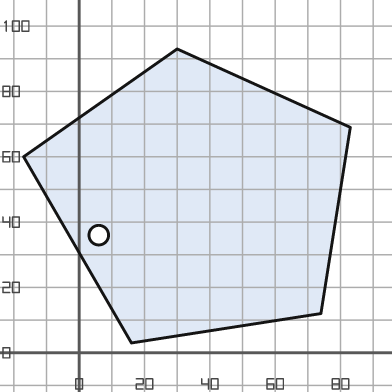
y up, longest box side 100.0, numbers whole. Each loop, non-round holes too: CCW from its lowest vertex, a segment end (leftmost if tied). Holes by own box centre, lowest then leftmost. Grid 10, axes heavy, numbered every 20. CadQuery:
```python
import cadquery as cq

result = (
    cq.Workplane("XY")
    .moveTo(16.0, 3.0)
    .lineTo(74.0, 12.0)
    .lineTo(83.0, 69.0)
    .lineTo(30.0, 93.0)
    .lineTo(-17.0, 60.0)
    .close()
    .moveTo(6.0, 36.0)
    .circle(3.0)
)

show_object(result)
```